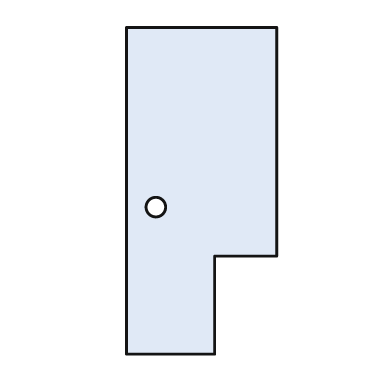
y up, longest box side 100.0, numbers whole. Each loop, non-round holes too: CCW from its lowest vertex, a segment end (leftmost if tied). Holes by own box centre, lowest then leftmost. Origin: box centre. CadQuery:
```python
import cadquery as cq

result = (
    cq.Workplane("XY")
    .moveTo(-23.0, -50.0)
    .lineTo(4.0, -50.0)
    .lineTo(4.0, -20.0)
    .lineTo(23.0, -20.0)
    .lineTo(23.0, 50.0)
    .lineTo(-23.0, 50.0)
    .close()
    .moveTo(-14.0, -5.0)
    .circle(3.0)
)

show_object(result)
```